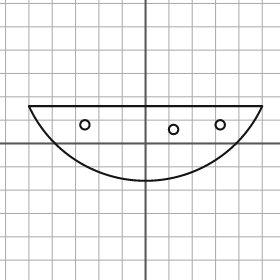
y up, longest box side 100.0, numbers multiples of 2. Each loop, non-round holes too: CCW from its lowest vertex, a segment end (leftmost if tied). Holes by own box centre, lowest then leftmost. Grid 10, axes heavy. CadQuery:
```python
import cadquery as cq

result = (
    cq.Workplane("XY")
    .moveTo(-50.0, 16.0)
    .threePointArc((0.0, -16.0), (50.0, 16.0))
    .close()
    .moveTo(12.0, 6.0)
    .circle(2.0)
    .moveTo(-26.0, 8.0)
    .circle(2.0)
    .moveTo(32.0, 8.0)
    .circle(2.0)
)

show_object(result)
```